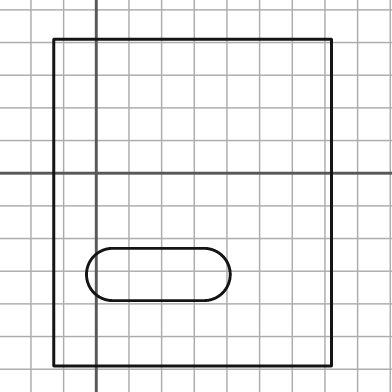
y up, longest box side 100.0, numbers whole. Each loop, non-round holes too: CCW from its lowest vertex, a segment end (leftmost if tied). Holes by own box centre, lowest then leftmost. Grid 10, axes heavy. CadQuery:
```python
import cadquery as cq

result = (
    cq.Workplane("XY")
    .moveTo(-13.0, -59.0)
    .lineTo(72.0, -59.0)
    .lineTo(72.0, 41.0)
    .lineTo(-13.0, 41.0)
    .close()
    .moveTo(5.0, -39.0)
    .lineTo(33.0, -39.0)
    .threePointArc((41.0, -31.0), (33.0, -23.0))
    .lineTo(5.0, -23.0)
    .threePointArc((-3.0, -31.0), (5.0, -39.0))
    .close()
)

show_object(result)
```